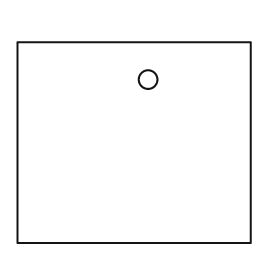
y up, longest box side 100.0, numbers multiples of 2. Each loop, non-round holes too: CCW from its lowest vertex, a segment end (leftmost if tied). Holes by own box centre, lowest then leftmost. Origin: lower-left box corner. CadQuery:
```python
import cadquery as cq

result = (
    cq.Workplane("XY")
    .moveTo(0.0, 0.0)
    .lineTo(100.0, 0.0)
    .lineTo(100.0, 86.0)
    .lineTo(0.0, 86.0)
    .close()
    .moveTo(56.0, 70.0)
    .circle(4.0)
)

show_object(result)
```